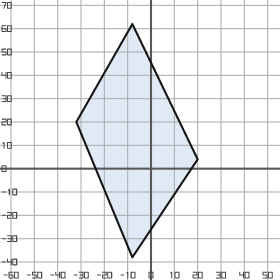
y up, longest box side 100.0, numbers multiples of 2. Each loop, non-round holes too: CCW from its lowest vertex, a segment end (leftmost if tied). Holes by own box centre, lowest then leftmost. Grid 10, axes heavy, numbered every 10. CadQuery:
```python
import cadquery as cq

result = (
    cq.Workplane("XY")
    .moveTo(-8.0, -38.0)
    .lineTo(20.0, 4.0)
    .lineTo(-8.0, 62.0)
    .lineTo(-32.0, 20.0)
    .close()
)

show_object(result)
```